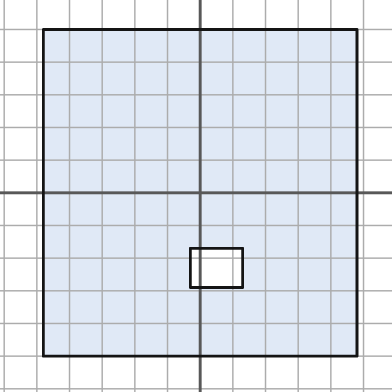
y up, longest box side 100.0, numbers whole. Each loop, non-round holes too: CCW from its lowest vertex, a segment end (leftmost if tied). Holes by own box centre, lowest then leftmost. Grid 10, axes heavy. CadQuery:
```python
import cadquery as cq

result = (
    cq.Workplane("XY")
    .moveTo(-48.0, -50.0)
    .lineTo(48.0, -50.0)
    .lineTo(48.0, 50.0)
    .lineTo(-48.0, 50.0)
    .close()
    .moveTo(-3.0, -29.0)
    .lineTo(13.0, -29.0)
    .lineTo(13.0, -17.0)
    .lineTo(-3.0, -17.0)
    .close()
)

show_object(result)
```